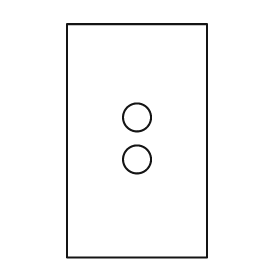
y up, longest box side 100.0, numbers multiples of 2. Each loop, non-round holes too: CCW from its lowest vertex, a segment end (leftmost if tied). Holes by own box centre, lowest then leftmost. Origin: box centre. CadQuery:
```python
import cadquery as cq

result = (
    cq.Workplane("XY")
    .moveTo(-30.0, -50.0)
    .lineTo(30.0, -50.0)
    .lineTo(30.0, 50.0)
    .lineTo(-30.0, 50.0)
    .close()
    .moveTo(0.0, -8.0)
    .circle(6.0)
    .moveTo(0.0, 10.0)
    .circle(6.0)
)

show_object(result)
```